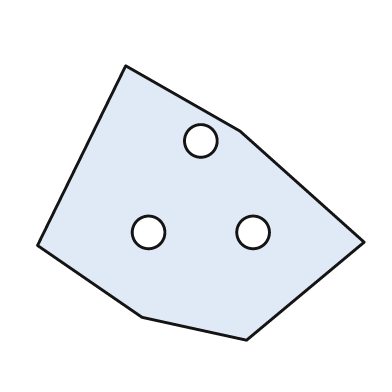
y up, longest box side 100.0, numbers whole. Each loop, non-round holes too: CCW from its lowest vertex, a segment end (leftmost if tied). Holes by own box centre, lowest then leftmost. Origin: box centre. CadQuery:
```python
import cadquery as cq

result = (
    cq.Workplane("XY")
    .moveTo(14.0, -42.0)
    .lineTo(50.0, -12.0)
    .lineTo(12.0, 22.0)
    .lineTo(-23.0, 42.0)
    .lineTo(-50.0, -13.0)
    .lineTo(-18.0, -35.0)
    .close()
    .moveTo(-16.0, -9.0)
    .circle(5.0)
    .moveTo(16.0, -9.0)
    .circle(5.0)
    .moveTo(0.0, 19.0)
    .circle(5.0)
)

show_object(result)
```